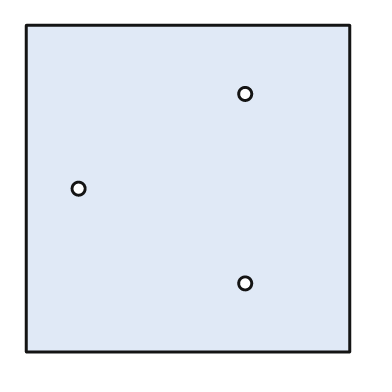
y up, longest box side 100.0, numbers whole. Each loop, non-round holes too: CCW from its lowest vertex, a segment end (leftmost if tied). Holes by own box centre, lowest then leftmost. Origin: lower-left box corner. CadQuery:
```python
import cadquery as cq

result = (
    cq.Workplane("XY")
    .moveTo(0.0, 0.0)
    .lineTo(99.0, 0.0)
    .lineTo(99.0, 100.0)
    .lineTo(0.0, 100.0)
    .close()
    .moveTo(67.0, 21.0)
    .circle(2.0)
    .moveTo(16.0, 50.0)
    .circle(2.0)
    .moveTo(67.0, 79.0)
    .circle(2.0)
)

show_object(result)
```